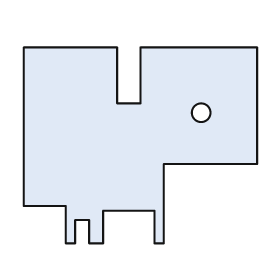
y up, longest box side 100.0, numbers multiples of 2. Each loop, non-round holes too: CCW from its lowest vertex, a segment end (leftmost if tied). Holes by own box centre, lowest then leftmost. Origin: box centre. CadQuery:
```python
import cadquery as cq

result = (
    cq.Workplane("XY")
    .moveTo(-32.0, -42.0)
    .lineTo(-28.0, -42.0)
    .lineTo(-28.0, -32.0)
    .lineTo(-22.0, -32.0)
    .lineTo(-22.0, -42.0)
    .lineTo(-16.0, -42.0)
    .lineTo(-16.0, -28.0)
    .lineTo(6.0, -28.0)
    .lineTo(6.0, -42.0)
    .lineTo(10.0, -42.0)
    .lineTo(10.0, -8.0)
    .lineTo(50.0, -8.0)
    .lineTo(50.0, 42.0)
    .lineTo(0.0, 42.0)
    .lineTo(0.0, 18.0)
    .lineTo(-10.0, 18.0)
    .lineTo(-10.0, 42.0)
    .lineTo(-50.0, 42.0)
    .lineTo(-50.0, -26.0)
    .lineTo(-32.0, -26.0)
    .close()
    .moveTo(26.0, 14.0)
    .circle(4.0)
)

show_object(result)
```